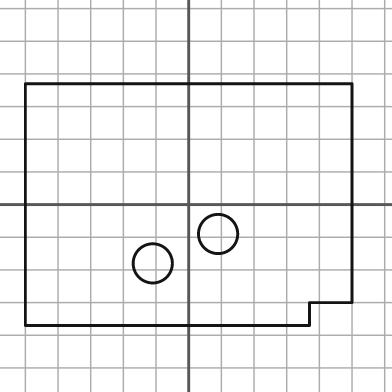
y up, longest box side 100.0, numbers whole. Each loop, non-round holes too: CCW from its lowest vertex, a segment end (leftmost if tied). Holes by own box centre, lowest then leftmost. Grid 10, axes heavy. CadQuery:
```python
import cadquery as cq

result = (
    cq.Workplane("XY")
    .moveTo(-50.0, -37.0)
    .lineTo(37.0, -37.0)
    .lineTo(37.0, -30.0)
    .lineTo(50.0, -30.0)
    .lineTo(50.0, 37.0)
    .lineTo(-50.0, 37.0)
    .close()
    .moveTo(-11.0, -18.0)
    .circle(6.0)
    .moveTo(9.0, -9.0)
    .circle(6.0)
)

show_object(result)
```